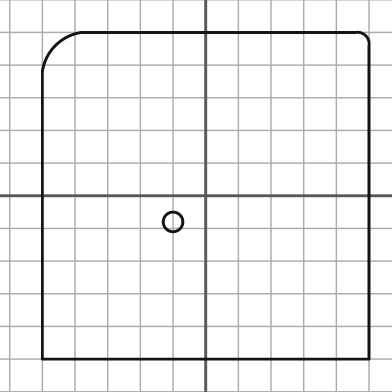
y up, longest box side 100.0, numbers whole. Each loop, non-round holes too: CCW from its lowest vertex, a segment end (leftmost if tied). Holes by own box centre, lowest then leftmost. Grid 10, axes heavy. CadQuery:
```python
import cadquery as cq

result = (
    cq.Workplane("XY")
    .moveTo(-50.0, -50.0)
    .lineTo(50.0, -50.0)
    .lineTo(50.0, 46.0)
    .threePointArc((49.0, 49.0), (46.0, 50.0))
    .lineTo(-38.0, 50.0)
    .threePointArc((-46.0, 46.0), (-50.0, 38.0))
    .close()
    .moveTo(-10.0, -8.0)
    .circle(3.0)
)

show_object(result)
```